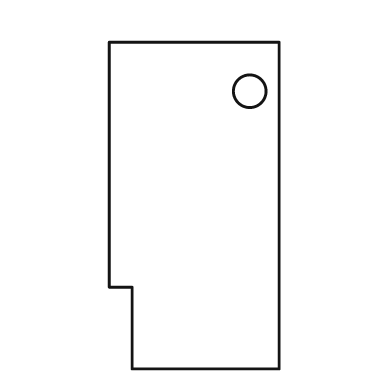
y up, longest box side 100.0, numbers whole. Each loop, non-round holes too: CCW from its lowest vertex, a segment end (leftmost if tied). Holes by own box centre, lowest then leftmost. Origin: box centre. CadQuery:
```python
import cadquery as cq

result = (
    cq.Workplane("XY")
    .moveTo(-19.0, -50.0)
    .lineTo(26.0, -50.0)
    .lineTo(26.0, 50.0)
    .lineTo(-26.0, 50.0)
    .lineTo(-26.0, -25.0)
    .lineTo(-19.0, -25.0)
    .close()
    .moveTo(17.0, 35.0)
    .circle(5.0)
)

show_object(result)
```